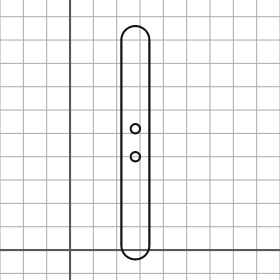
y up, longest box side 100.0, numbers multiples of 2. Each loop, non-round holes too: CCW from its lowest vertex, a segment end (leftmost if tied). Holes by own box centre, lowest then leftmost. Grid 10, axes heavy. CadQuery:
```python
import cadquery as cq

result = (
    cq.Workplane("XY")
    .moveTo(22.0, 2.0)
    .threePointArc((28.0, -4.0), (34.0, 2.0))
    .lineTo(34.0, 90.0)
    .threePointArc((28.0, 96.0), (22.0, 90.0))
    .close()
    .moveTo(28.0, 40.0)
    .circle(2.0)
    .moveTo(28.0, 52.0)
    .circle(2.0)
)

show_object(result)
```